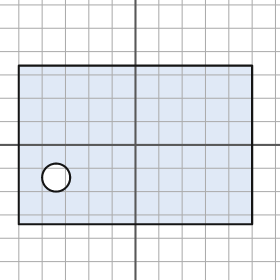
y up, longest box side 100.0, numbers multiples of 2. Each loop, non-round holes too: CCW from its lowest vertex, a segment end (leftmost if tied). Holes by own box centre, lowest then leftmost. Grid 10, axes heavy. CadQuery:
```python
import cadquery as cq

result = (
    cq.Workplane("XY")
    .moveTo(-50.0, -34.0)
    .lineTo(50.0, -34.0)
    .lineTo(50.0, 34.0)
    .lineTo(-50.0, 34.0)
    .close()
    .moveTo(-34.0, -14.0)
    .circle(6.0)
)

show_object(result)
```